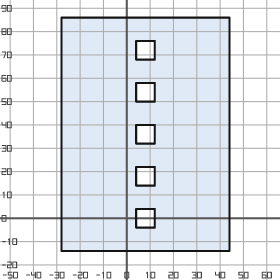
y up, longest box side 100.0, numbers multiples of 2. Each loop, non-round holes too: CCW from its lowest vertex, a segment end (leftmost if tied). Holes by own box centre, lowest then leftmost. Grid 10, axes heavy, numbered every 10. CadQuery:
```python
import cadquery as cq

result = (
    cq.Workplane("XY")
    .moveTo(-28.0, -14.0)
    .lineTo(44.0, -14.0)
    .lineTo(44.0, 86.0)
    .lineTo(-28.0, 86.0)
    .close()
    .moveTo(4.0, -4.0)
    .lineTo(12.0, -4.0)
    .lineTo(12.0, 4.0)
    .lineTo(4.0, 4.0)
    .close()
    .moveTo(4.0, 14.0)
    .lineTo(12.0, 14.0)
    .lineTo(12.0, 22.0)
    .lineTo(4.0, 22.0)
    .close()
    .moveTo(4.0, 32.0)
    .lineTo(12.0, 32.0)
    .lineTo(12.0, 40.0)
    .lineTo(4.0, 40.0)
    .close()
    .moveTo(4.0, 50.0)
    .lineTo(12.0, 50.0)
    .lineTo(12.0, 58.0)
    .lineTo(4.0, 58.0)
    .close()
    .moveTo(4.0, 68.0)
    .lineTo(12.0, 68.0)
    .lineTo(12.0, 76.0)
    .lineTo(4.0, 76.0)
    .close()
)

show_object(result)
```